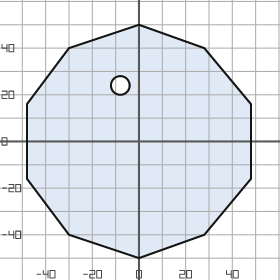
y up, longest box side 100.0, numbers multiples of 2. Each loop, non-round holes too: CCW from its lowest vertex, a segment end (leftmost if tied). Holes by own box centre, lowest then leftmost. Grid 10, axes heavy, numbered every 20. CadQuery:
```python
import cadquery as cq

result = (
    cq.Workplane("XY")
    .moveTo(0.0, -50.0)
    .lineTo(28.0, -40.0)
    .lineTo(48.0, -16.0)
    .lineTo(48.0, 16.0)
    .lineTo(28.0, 40.0)
    .lineTo(0.0, 50.0)
    .lineTo(-30.0, 40.0)
    .lineTo(-48.0, 16.0)
    .lineTo(-48.0, -16.0)
    .lineTo(-30.0, -40.0)
    .close()
    .moveTo(-8.0, 24.0)
    .circle(4.0)
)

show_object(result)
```